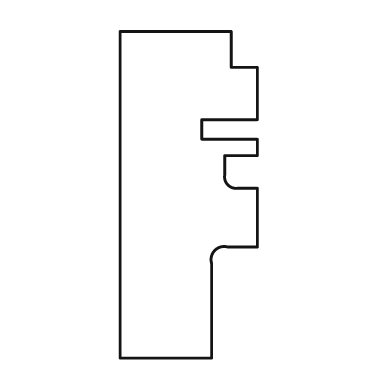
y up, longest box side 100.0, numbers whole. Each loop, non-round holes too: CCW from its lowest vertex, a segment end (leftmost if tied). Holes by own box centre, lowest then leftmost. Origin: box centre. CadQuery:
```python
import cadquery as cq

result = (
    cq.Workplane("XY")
    .moveTo(-21.0, -50.0)
    .lineTo(7.0, -50.0)
    .lineTo(7.0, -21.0)
    .threePointArc((8.0, -17.0), (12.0, -16.0))
    .lineTo(21.0, -16.0)
    .lineTo(21.0, 2.0)
    .lineTo(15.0, 2.0)
    .threePointArc((12.0, 3.0), (11.0, 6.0))
    .lineTo(11.0, 12.0)
    .lineTo(21.0, 12.0)
    .lineTo(21.0, 17.0)
    .lineTo(4.0, 17.0)
    .lineTo(4.0, 23.0)
    .lineTo(21.0, 23.0)
    .lineTo(21.0, 39.0)
    .lineTo(13.0, 39.0)
    .lineTo(13.0, 50.0)
    .lineTo(-21.0, 50.0)
    .close()
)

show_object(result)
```